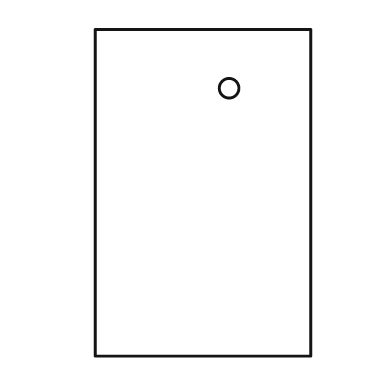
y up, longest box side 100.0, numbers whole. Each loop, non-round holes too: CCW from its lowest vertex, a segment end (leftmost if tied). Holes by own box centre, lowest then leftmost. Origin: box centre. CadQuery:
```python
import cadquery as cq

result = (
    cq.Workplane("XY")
    .moveTo(-33.0, -50.0)
    .lineTo(33.0, -50.0)
    .lineTo(33.0, 50.0)
    .lineTo(-33.0, 50.0)
    .close()
    .moveTo(8.0, 32.0)
    .circle(3.0)
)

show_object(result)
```